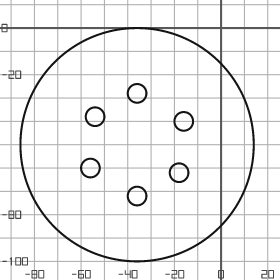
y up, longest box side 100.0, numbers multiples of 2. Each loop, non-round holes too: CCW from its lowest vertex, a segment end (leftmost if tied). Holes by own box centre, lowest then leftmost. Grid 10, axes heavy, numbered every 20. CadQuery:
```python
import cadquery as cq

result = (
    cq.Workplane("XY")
    .moveTo(-36.0, -50.0)
    .circle(50.0)
    .moveTo(-36.0, -72.0)
    .circle(4.0)
    .moveTo(-18.0, -62.0)
    .circle(4.0)
    .moveTo(-56.0, -60.0)
    .circle(4.0)
    .moveTo(-16.0, -40.0)
    .circle(4.0)
    .moveTo(-54.0, -38.0)
    .circle(4.0)
    .moveTo(-36.0, -28.0)
    .circle(4.0)
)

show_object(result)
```